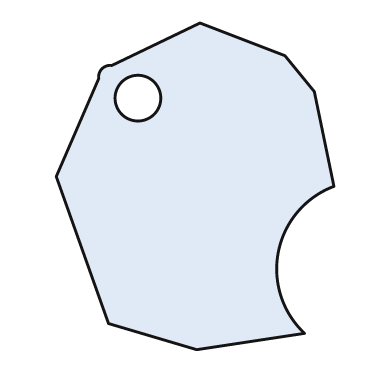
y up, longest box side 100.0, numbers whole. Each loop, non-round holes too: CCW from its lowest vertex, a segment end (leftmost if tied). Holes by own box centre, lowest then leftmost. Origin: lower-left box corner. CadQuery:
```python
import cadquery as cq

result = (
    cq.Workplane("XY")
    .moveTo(43.0, 0.0)
    .lineTo(76.0, 5.0)
    .threePointArc((68.0, 30.0), (85.0, 50.0))
    .lineTo(79.0, 79.0)
    .lineTo(70.0, 90.0)
    .lineTo(44.0, 100.0)
    .lineTo(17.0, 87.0)
    .threePointArc((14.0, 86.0), (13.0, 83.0))
    .lineTo(0.0, 53.0)
    .lineTo(16.0, 8.0)
    .close()
    .moveTo(25.0, 77.0)
    .circle(7.0)
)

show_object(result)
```